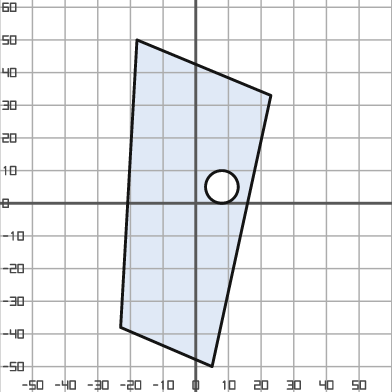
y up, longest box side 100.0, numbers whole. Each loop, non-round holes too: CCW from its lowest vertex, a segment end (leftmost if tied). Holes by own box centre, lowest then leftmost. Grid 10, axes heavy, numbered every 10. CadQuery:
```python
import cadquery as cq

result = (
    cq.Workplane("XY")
    .moveTo(5.0, -50.0)
    .lineTo(23.0, 33.0)
    .lineTo(-18.0, 50.0)
    .lineTo(-23.0, -38.0)
    .close()
    .moveTo(8.0, 5.0)
    .circle(5.0)
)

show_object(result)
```